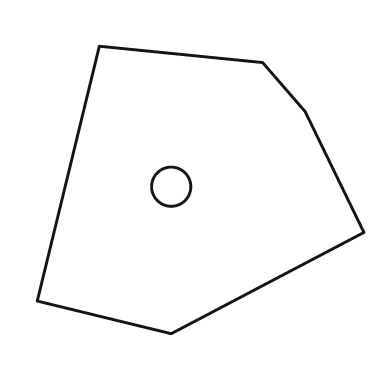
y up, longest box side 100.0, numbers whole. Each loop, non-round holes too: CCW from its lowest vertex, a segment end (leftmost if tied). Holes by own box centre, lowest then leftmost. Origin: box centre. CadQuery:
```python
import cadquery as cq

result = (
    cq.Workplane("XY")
    .moveTo(-9.0, -44.0)
    .lineTo(50.0, -13.0)
    .lineTo(32.0, 24.0)
    .lineTo(19.0, 39.0)
    .lineTo(-31.0, 44.0)
    .lineTo(-50.0, -34.0)
    .close()
    .moveTo(-9.0, 1.0)
    .circle(6.0)
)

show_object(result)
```